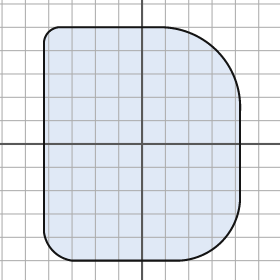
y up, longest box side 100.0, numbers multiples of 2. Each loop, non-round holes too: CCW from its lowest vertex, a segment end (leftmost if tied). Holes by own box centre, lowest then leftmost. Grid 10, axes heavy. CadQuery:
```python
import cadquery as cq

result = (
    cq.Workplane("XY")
    .moveTo(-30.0, -50.0)
    .lineTo(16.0, -50.0)
    .threePointArc((34.0, -42.0), (42.0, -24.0))
    .lineTo(42.0, 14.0)
    .threePointArc((32.0, 40.0), (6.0, 50.0))
    .lineTo(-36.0, 50.0)
    .threePointArc((-40.0, 48.0), (-42.0, 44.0))
    .lineTo(-42.0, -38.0)
    .threePointArc((-38.0, -46.0), (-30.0, -50.0))
    .close()
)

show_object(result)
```